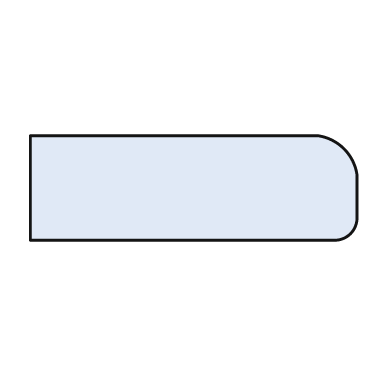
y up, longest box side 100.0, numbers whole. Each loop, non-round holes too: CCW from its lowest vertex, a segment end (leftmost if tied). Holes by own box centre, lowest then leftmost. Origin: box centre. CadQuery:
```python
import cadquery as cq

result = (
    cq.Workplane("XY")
    .moveTo(-50.0, -16.0)
    .lineTo(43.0, -16.0)
    .threePointArc((48.0, -14.0), (50.0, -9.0))
    .lineTo(50.0, 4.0)
    .threePointArc((46.0, 12.0), (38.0, 16.0))
    .lineTo(-50.0, 16.0)
    .close()
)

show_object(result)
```